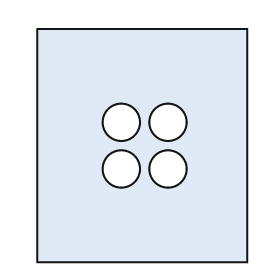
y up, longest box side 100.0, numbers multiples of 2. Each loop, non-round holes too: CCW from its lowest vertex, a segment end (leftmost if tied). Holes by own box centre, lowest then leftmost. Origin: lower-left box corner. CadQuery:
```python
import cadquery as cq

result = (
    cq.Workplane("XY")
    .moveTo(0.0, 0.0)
    .lineTo(90.0, 0.0)
    .lineTo(90.0, 100.0)
    .lineTo(0.0, 100.0)
    .close()
    .moveTo(36.0, 40.0)
    .circle(8.0)
    .moveTo(56.0, 40.0)
    .circle(8.0)
    .moveTo(36.0, 60.0)
    .circle(8.0)
    .moveTo(56.0, 60.0)
    .circle(8.0)
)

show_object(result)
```